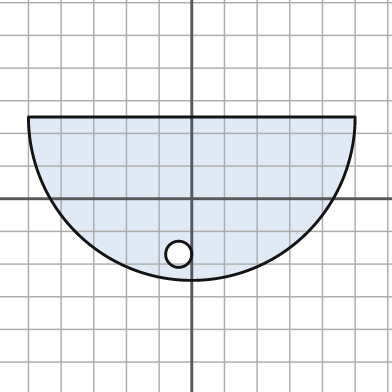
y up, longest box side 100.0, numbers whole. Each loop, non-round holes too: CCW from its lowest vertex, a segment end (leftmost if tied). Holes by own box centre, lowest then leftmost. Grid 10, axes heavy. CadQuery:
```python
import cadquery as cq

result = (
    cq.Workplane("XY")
    .moveTo(-50.0, 25.0)
    .threePointArc((0.0, -25.0), (50.0, 25.0))
    .close()
    .moveTo(-4.0, -17.0)
    .circle(4.0)
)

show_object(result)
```